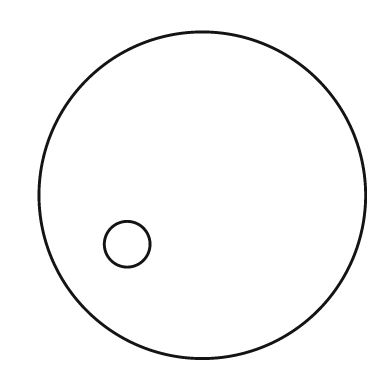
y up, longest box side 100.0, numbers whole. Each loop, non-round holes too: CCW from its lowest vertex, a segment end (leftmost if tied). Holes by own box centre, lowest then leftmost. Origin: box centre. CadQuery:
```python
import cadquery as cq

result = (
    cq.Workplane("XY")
    .moveTo(0.0, 0.0)
    .circle(50.0)
    .moveTo(-23.0, -15.0)
    .circle(7.0)
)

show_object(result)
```